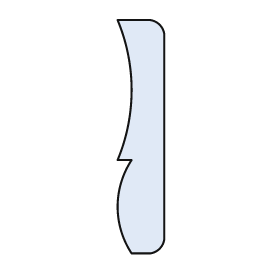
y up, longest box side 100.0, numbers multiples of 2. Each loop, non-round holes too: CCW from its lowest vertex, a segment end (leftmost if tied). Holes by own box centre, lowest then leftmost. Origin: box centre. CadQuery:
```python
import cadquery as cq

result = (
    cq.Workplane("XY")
    .moveTo(-4.0, -50.0)
    .lineTo(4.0, -50.0)
    .threePointArc((8.0, -48.0), (10.0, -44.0))
    .lineTo(10.0, 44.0)
    .threePointArc((8.0, 48.0), (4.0, 50.0))
    .lineTo(-10.0, 50.0)
    .threePointArc((-4.0, 20.0), (-10.0, -10.0))
    .lineTo(-4.0, -10.0)
    .threePointArc((-10.0, -30.0), (-4.0, -50.0))
    .close()
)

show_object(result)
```